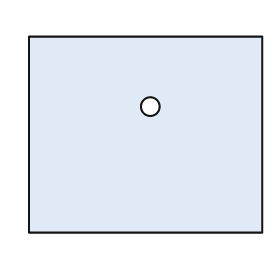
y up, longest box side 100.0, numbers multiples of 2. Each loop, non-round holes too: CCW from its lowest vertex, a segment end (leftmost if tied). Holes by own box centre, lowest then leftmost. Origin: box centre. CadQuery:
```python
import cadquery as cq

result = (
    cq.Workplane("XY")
    .moveTo(-50.0, -42.0)
    .lineTo(50.0, -42.0)
    .lineTo(50.0, 42.0)
    .lineTo(-50.0, 42.0)
    .close()
    .moveTo(2.0, 12.0)
    .circle(4.0)
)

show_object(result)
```